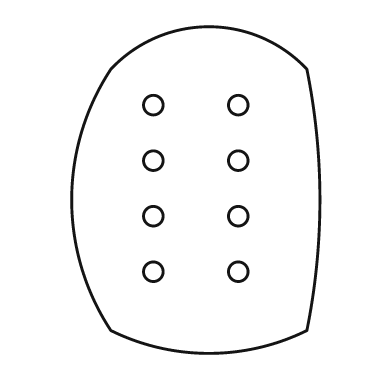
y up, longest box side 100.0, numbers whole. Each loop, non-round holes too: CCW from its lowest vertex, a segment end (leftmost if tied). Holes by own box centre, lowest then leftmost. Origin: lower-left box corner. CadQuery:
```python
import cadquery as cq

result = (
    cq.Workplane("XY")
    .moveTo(12.0, 7.0)
    .threePointArc((42.0, 0.0), (72.0, 7.0))
    .threePointArc((76.0, 47.0), (72.0, 87.0))
    .threePointArc((42.0, 100.0), (12.0, 87.0))
    .threePointArc((0.0, 47.0), (12.0, 7.0))
    .close()
    .moveTo(25.0, 25.0)
    .circle(3.0)
    .moveTo(51.0, 25.0)
    .circle(3.0)
    .moveTo(25.0, 42.0)
    .circle(3.0)
    .moveTo(51.0, 42.0)
    .circle(3.0)
    .moveTo(25.0, 59.0)
    .circle(3.0)
    .moveTo(51.0, 59.0)
    .circle(3.0)
    .moveTo(25.0, 76.0)
    .circle(3.0)
    .moveTo(51.0, 76.0)
    .circle(3.0)
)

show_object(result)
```